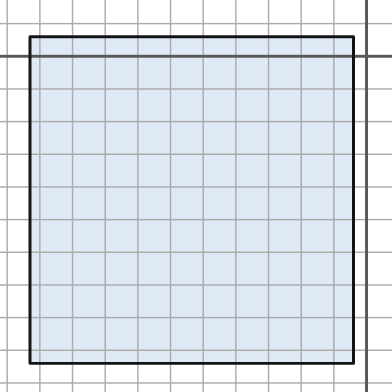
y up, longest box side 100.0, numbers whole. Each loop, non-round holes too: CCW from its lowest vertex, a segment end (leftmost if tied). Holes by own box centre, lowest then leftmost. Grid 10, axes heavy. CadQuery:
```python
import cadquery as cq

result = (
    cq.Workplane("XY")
    .moveTo(-103.0, -94.0)
    .lineTo(-4.0, -94.0)
    .lineTo(-4.0, 6.0)
    .lineTo(-103.0, 6.0)
    .close()
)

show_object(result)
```